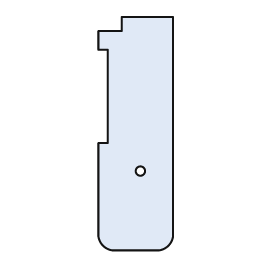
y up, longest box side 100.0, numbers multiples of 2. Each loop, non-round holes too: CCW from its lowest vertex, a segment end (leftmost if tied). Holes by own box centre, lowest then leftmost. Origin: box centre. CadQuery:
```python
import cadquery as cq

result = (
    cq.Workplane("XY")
    .moveTo(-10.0, -50.0)
    .lineTo(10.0, -50.0)
    .threePointArc((14.0, -48.0), (16.0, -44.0))
    .lineTo(16.0, 50.0)
    .lineTo(-6.0, 50.0)
    .lineTo(-6.0, 44.0)
    .lineTo(-16.0, 44.0)
    .lineTo(-16.0, 36.0)
    .lineTo(-12.0, 36.0)
    .lineTo(-12.0, -4.0)
    .lineTo(-16.0, -4.0)
    .lineTo(-16.0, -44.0)
    .threePointArc((-14.0, -48.0), (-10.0, -50.0))
    .close()
    .moveTo(2.0, -16.0)
    .circle(2.0)
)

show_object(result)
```